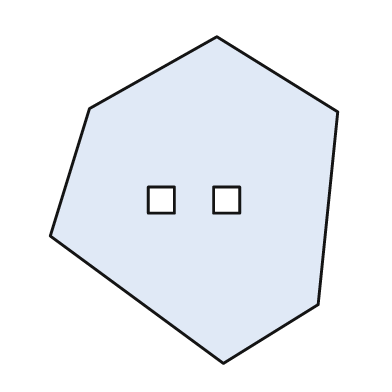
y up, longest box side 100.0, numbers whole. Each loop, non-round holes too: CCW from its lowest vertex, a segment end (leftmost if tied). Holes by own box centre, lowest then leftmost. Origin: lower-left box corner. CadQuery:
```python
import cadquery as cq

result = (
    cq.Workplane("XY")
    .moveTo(53.0, 0.0)
    .lineTo(82.0, 18.0)
    .lineTo(88.0, 77.0)
    .lineTo(51.0, 100.0)
    .lineTo(12.0, 78.0)
    .lineTo(0.0, 39.0)
    .close()
    .moveTo(30.0, 46.0)
    .lineTo(38.0, 46.0)
    .lineTo(38.0, 54.0)
    .lineTo(30.0, 54.0)
    .close()
    .moveTo(50.0, 46.0)
    .lineTo(58.0, 46.0)
    .lineTo(58.0, 54.0)
    .lineTo(50.0, 54.0)
    .close()
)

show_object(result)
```